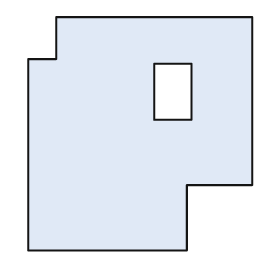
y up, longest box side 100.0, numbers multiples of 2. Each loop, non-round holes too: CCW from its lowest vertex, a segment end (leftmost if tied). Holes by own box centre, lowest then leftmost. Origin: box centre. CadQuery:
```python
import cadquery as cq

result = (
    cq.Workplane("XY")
    .moveTo(-48.0, -50.0)
    .lineTo(20.0, -50.0)
    .lineTo(20.0, -22.0)
    .lineTo(48.0, -22.0)
    .lineTo(48.0, 50.0)
    .lineTo(-36.0, 50.0)
    .lineTo(-36.0, 32.0)
    .lineTo(-48.0, 32.0)
    .close()
    .moveTo(6.0, 6.0)
    .lineTo(22.0, 6.0)
    .lineTo(22.0, 30.0)
    .lineTo(6.0, 30.0)
    .close()
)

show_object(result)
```